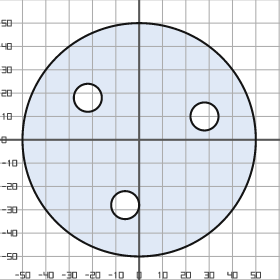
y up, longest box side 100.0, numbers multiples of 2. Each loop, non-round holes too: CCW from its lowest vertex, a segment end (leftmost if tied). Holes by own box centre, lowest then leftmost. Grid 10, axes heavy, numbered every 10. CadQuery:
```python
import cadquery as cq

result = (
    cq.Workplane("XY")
    .moveTo(0.0, 0.0)
    .circle(50.0)
    .moveTo(-6.0, -28.0)
    .circle(6.0)
    .moveTo(28.0, 10.0)
    .circle(6.0)
    .moveTo(-22.0, 18.0)
    .circle(6.0)
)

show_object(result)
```